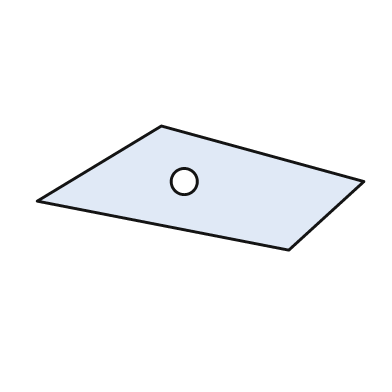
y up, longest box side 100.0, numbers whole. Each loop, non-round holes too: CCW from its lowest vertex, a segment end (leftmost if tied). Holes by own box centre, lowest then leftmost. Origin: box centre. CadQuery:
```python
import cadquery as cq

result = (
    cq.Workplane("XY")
    .moveTo(27.0, -19.0)
    .lineTo(50.0, 2.0)
    .lineTo(-12.0, 19.0)
    .lineTo(-50.0, -4.0)
    .close()
    .moveTo(-5.0, 2.0)
    .circle(4.0)
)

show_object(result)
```